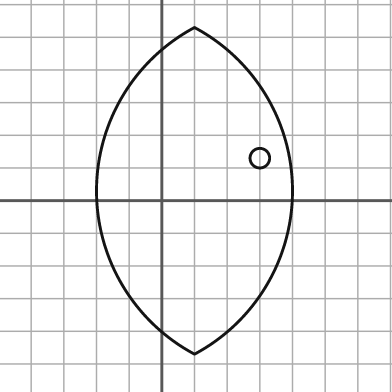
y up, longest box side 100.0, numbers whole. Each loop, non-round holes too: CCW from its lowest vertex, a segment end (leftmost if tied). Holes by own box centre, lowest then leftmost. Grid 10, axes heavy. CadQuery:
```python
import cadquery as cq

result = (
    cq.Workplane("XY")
    .moveTo(10.0, -47.0)
    .threePointArc((40.0, 3.0), (10.0, 53.0))
    .threePointArc((-20.0, 3.0), (10.0, -47.0))
    .close()
    .moveTo(30.0, 13.0)
    .circle(3.0)
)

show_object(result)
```